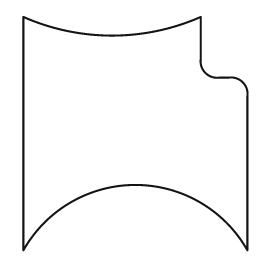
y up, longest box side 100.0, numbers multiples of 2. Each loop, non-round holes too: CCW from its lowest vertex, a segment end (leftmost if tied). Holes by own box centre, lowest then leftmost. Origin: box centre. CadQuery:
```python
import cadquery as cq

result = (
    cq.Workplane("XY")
    .moveTo(-48.0, -50.0)
    .threePointArc((0.0, -22.0), (48.0, -50.0))
    .lineTo(48.0, 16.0)
    .threePointArc((46.0, 22.0), (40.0, 24.0))
    .lineTo(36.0, 24.0)
    .threePointArc((30.0, 26.0), (28.0, 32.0))
    .lineTo(28.0, 50.0)
    .threePointArc((-10.0, 42.0), (-48.0, 50.0))
    .close()
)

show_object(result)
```